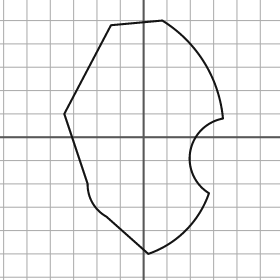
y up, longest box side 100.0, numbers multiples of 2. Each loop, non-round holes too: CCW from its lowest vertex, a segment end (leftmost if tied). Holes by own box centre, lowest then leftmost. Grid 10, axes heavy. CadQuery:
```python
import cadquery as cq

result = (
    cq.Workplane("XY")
    .moveTo(2.0, -50.0)
    .threePointArc((18.0, -40.0), (28.0, -24.0))
    .threePointArc((20.0, -6.0), (34.0, 8.0))
    .threePointArc((26.0, 32.0), (8.0, 50.0))
    .lineTo(-14.0, 48.0)
    .lineTo(-34.0, 10.0)
    .lineTo(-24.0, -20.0)
    .threePointArc((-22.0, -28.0), (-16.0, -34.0))
    .close()
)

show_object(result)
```